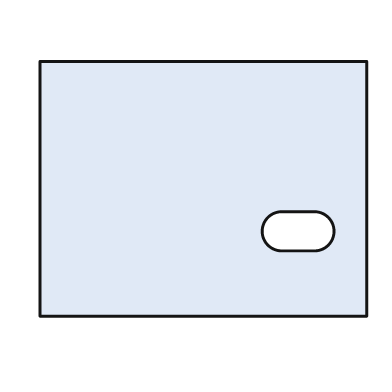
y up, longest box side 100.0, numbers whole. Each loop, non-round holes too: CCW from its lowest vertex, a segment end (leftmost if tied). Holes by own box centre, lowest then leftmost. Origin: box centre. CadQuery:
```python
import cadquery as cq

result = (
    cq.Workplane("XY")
    .moveTo(-50.0, -39.0)
    .lineTo(50.0, -39.0)
    .lineTo(50.0, 39.0)
    .lineTo(-50.0, 39.0)
    .close()
    .moveTo(24.0, -19.0)
    .lineTo(34.0, -19.0)
    .threePointArc((40.0, -13.0), (34.0, -7.0))
    .lineTo(24.0, -7.0)
    .threePointArc((18.0, -13.0), (24.0, -19.0))
    .close()
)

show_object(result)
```